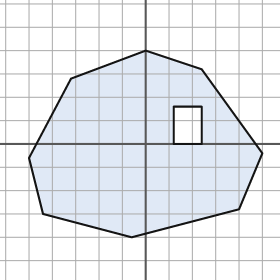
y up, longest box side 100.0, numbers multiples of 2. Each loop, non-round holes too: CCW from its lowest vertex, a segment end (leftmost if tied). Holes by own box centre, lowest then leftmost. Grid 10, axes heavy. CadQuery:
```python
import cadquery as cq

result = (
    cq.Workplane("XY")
    .moveTo(-6.0, -40.0)
    .lineTo(40.0, -28.0)
    .lineTo(50.0, -4.0)
    .lineTo(24.0, 32.0)
    .lineTo(0.0, 40.0)
    .lineTo(-32.0, 28.0)
    .lineTo(-50.0, -6.0)
    .lineTo(-44.0, -30.0)
    .close()
    .moveTo(12.0, 0.0)
    .lineTo(24.0, 0.0)
    .lineTo(24.0, 16.0)
    .lineTo(12.0, 16.0)
    .close()
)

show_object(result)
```